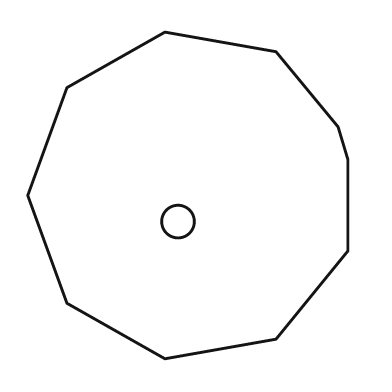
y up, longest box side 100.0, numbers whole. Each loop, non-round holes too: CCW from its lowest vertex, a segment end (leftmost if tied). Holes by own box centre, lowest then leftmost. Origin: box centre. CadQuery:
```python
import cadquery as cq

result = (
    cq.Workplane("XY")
    .moveTo(-7.0, -50.0)
    .lineTo(27.0, -44.0)
    .lineTo(49.0, -17.0)
    .lineTo(49.0, 11.0)
    .lineTo(46.0, 21.0)
    .lineTo(27.0, 44.0)
    .lineTo(-7.0, 50.0)
    .lineTo(-37.0, 33.0)
    .lineTo(-49.0, 0.0)
    .lineTo(-37.0, -33.0)
    .close()
    .moveTo(-3.0, -8.0)
    .circle(5.0)
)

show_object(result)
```